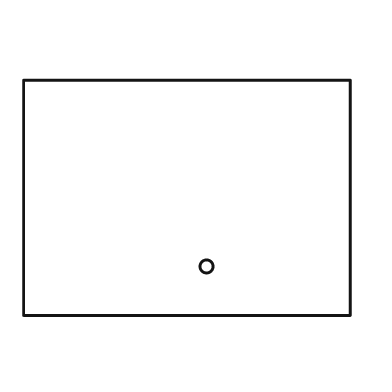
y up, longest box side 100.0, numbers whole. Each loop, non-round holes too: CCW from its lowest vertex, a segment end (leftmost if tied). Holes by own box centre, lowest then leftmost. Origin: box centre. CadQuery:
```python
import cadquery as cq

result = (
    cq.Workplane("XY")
    .moveTo(-50.0, -36.0)
    .lineTo(50.0, -36.0)
    .lineTo(50.0, 36.0)
    .lineTo(-50.0, 36.0)
    .close()
    .moveTo(6.0, -21.0)
    .circle(2.0)
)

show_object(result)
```